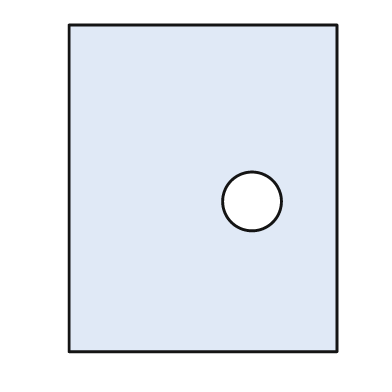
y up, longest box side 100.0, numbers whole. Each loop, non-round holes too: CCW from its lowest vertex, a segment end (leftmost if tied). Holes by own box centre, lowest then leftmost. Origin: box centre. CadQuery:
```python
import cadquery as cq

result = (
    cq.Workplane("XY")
    .moveTo(-41.0, -50.0)
    .lineTo(41.0, -50.0)
    .lineTo(41.0, 50.0)
    .lineTo(-41.0, 50.0)
    .close()
    .moveTo(15.0, -4.0)
    .circle(9.0)
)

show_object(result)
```